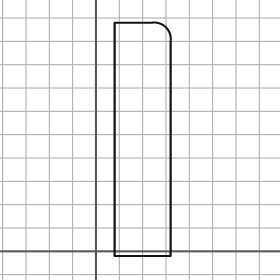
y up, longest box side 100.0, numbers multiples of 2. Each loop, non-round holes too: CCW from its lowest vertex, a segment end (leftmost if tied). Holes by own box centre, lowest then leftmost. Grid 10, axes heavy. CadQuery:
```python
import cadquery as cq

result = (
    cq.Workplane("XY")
    .moveTo(8.0, -2.0)
    .lineTo(32.0, -2.0)
    .lineTo(32.0, 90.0)
    .threePointArc((30.0, 96.0), (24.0, 98.0))
    .lineTo(8.0, 98.0)
    .close()
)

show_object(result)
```